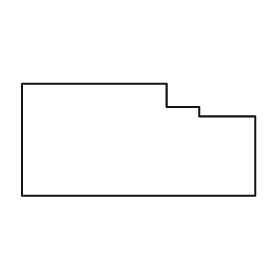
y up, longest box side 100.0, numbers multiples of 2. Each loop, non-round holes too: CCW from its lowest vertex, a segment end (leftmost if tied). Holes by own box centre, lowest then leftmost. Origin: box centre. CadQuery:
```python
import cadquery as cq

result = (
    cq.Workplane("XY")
    .moveTo(-50.0, -24.0)
    .lineTo(50.0, -24.0)
    .lineTo(50.0, 10.0)
    .lineTo(26.0, 10.0)
    .lineTo(26.0, 14.0)
    .lineTo(12.0, 14.0)
    .lineTo(12.0, 24.0)
    .lineTo(-50.0, 24.0)
    .close()
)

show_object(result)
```